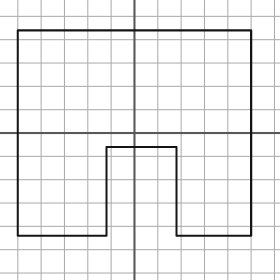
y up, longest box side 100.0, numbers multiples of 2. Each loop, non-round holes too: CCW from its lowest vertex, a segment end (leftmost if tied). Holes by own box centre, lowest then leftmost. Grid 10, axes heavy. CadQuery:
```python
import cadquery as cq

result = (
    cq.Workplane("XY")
    .moveTo(-50.0, -44.0)
    .lineTo(-12.0, -44.0)
    .lineTo(-12.0, -6.0)
    .lineTo(18.0, -6.0)
    .lineTo(18.0, -44.0)
    .lineTo(50.0, -44.0)
    .lineTo(50.0, 44.0)
    .lineTo(-50.0, 44.0)
    .close()
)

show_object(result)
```